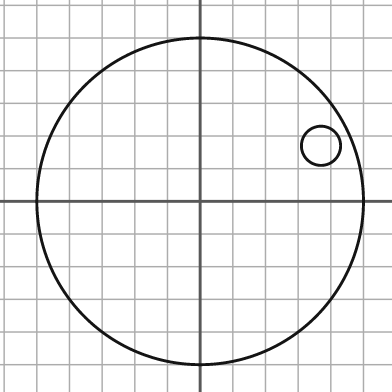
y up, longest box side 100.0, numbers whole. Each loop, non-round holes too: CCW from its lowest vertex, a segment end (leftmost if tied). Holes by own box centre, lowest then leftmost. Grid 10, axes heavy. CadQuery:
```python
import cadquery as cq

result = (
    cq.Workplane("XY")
    .moveTo(0.0, 0.0)
    .circle(50.0)
    .moveTo(37.0, 17.0)
    .circle(6.0)
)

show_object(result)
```